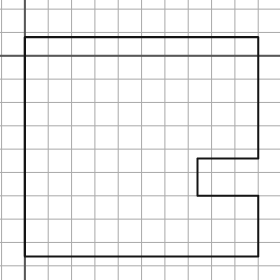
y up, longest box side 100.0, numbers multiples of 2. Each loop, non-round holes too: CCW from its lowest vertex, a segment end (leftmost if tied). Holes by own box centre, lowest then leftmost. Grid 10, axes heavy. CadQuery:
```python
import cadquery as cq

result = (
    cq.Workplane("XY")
    .moveTo(0.0, -86.0)
    .lineTo(100.0, -86.0)
    .lineTo(100.0, -60.0)
    .lineTo(74.0, -60.0)
    .lineTo(74.0, -44.0)
    .lineTo(100.0, -44.0)
    .lineTo(100.0, 8.0)
    .lineTo(0.0, 8.0)
    .close()
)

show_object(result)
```